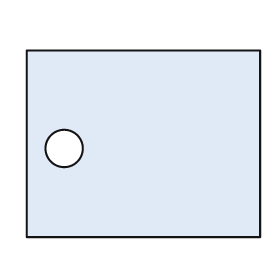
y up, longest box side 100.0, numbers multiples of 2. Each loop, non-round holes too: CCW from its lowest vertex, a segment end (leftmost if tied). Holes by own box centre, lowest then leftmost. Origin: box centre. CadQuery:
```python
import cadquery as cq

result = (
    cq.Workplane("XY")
    .moveTo(-50.0, -40.0)
    .lineTo(50.0, -40.0)
    .lineTo(50.0, 40.0)
    .lineTo(-50.0, 40.0)
    .close()
    .moveTo(-34.0, -2.0)
    .circle(8.0)
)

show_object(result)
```